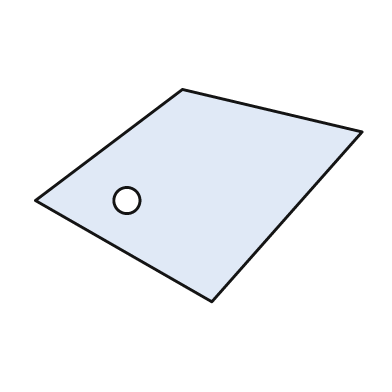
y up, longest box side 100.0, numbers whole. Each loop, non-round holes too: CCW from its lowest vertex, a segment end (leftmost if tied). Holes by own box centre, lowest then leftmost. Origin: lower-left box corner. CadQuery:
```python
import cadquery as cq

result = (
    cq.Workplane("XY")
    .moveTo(54.0, 0.0)
    .lineTo(100.0, 52.0)
    .lineTo(45.0, 65.0)
    .lineTo(0.0, 31.0)
    .close()
    .moveTo(28.0, 31.0)
    .circle(4.0)
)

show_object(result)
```